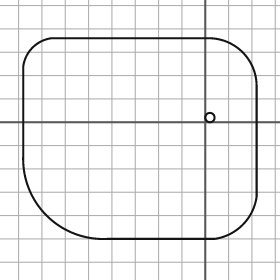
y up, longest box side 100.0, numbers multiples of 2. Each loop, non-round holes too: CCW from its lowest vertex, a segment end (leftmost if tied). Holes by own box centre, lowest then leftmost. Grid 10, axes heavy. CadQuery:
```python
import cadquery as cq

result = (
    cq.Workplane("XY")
    .moveTo(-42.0, -50.0)
    .lineTo(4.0, -50.0)
    .threePointArc((16.0, -44.0), (22.0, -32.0))
    .lineTo(22.0, 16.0)
    .threePointArc((16.0, 30.0), (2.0, 36.0))
    .lineTo(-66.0, 36.0)
    .threePointArc((-74.0, 32.0), (-78.0, 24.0))
    .lineTo(-78.0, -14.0)
    .threePointArc((-68.0, -40.0), (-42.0, -50.0))
    .close()
    .moveTo(2.0, 2.0)
    .circle(2.0)
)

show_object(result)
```